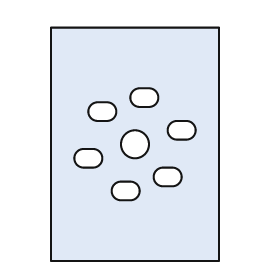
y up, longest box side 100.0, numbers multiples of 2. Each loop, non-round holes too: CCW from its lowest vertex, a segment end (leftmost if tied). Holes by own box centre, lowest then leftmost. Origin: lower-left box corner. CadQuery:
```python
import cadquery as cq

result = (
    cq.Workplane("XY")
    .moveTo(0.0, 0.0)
    .lineTo(72.0, 0.0)
    .lineTo(72.0, 100.0)
    .lineTo(0.0, 100.0)
    .close()
    .moveTo(30.0, 26.0)
    .lineTo(34.0, 26.0)
    .threePointArc((38.0, 30.0), (34.0, 34.0))
    .lineTo(30.0, 34.0)
    .threePointArc((26.0, 30.0), (30.0, 26.0))
    .close()
    .moveTo(48.0, 32.0)
    .lineTo(52.0, 32.0)
    .threePointArc((56.0, 36.0), (52.0, 40.0))
    .lineTo(48.0, 40.0)
    .threePointArc((44.0, 36.0), (48.0, 32.0))
    .close()
    .moveTo(14.0, 40.0)
    .lineTo(18.0, 40.0)
    .threePointArc((22.0, 44.0), (18.0, 48.0))
    .lineTo(14.0, 48.0)
    .threePointArc((10.0, 44.0), (14.0, 40.0))
    .close()
    .moveTo(36.0, 50.0)
    .circle(6.0)
    .moveTo(54.0, 52.0)
    .lineTo(58.0, 52.0)
    .threePointArc((62.0, 56.0), (58.0, 60.0))
    .lineTo(54.0, 60.0)
    .threePointArc((50.0, 56.0), (54.0, 52.0))
    .close()
    .moveTo(20.0, 60.0)
    .lineTo(24.0, 60.0)
    .threePointArc((28.0, 64.0), (24.0, 68.0))
    .lineTo(20.0, 68.0)
    .threePointArc((16.0, 64.0), (20.0, 60.0))
    .close()
    .moveTo(38.0, 66.0)
    .lineTo(42.0, 66.0)
    .threePointArc((46.0, 70.0), (42.0, 74.0))
    .lineTo(38.0, 74.0)
    .threePointArc((34.0, 70.0), (38.0, 66.0))
    .close()
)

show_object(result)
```